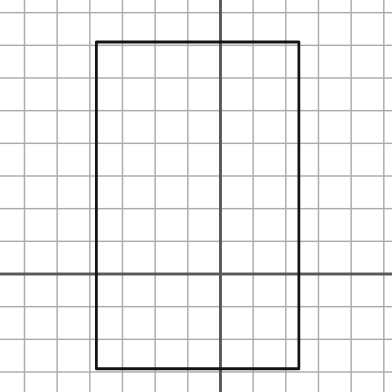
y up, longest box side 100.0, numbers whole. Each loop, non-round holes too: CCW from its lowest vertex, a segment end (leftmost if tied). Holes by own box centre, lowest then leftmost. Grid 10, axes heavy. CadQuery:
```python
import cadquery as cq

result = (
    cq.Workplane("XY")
    .moveTo(-38.0, -29.0)
    .lineTo(24.0, -29.0)
    .lineTo(24.0, 71.0)
    .lineTo(-38.0, 71.0)
    .close()
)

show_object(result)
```